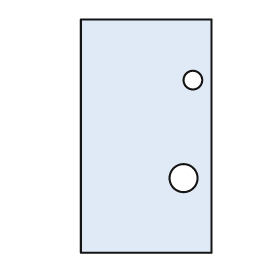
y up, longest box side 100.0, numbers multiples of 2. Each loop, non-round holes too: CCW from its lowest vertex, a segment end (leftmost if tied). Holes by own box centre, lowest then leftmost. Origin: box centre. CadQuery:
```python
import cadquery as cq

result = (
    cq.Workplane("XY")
    .moveTo(-28.0, -50.0)
    .lineTo(28.0, -50.0)
    .lineTo(28.0, 50.0)
    .lineTo(-28.0, 50.0)
    .close()
    .moveTo(16.0, -18.0)
    .circle(6.0)
    .moveTo(20.0, 24.0)
    .circle(4.0)
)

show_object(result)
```